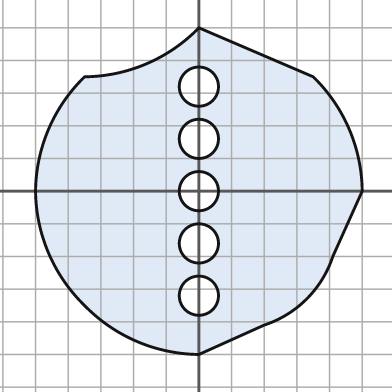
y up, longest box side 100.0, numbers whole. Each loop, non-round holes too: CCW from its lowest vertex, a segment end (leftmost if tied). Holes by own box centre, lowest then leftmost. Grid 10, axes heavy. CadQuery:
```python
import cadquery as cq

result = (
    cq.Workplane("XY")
    .moveTo(0.0, -50.0)
    .lineTo(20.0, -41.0)
    .threePointArc((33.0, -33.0), (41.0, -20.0))
    .lineTo(50.0, 0.0)
    .threePointArc((46.0, 19.0), (35.0, 35.0))
    .lineTo(0.0, 50.0)
    .threePointArc((-16.0, 39.0), (-35.0, 35.0))
    .threePointArc((-46.0, 19.0), (-50.0, 0.0))
    .threePointArc((-46.0, -19.0), (-35.0, -35.0))
    .threePointArc((-19.0, -46.0), (0.0, -50.0))
    .close()
    .moveTo(0.0, -32.0)
    .circle(6.0)
    .moveTo(0.0, -16.0)
    .circle(6.0)
    .moveTo(0.0, 0.0)
    .circle(6.0)
    .moveTo(0.0, 16.0)
    .circle(6.0)
    .moveTo(0.0, 32.0)
    .circle(6.0)
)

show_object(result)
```